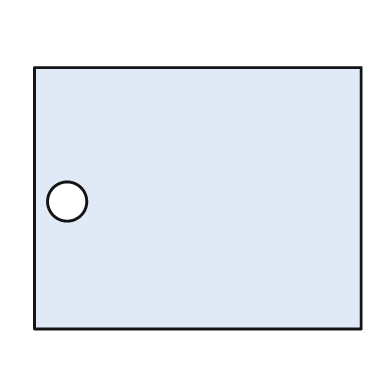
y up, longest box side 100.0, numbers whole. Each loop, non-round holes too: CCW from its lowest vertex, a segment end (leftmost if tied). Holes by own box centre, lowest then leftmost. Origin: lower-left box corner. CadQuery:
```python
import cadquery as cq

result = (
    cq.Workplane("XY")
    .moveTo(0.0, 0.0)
    .lineTo(100.0, 0.0)
    .lineTo(100.0, 80.0)
    .lineTo(0.0, 80.0)
    .close()
    .moveTo(10.0, 39.0)
    .circle(6.0)
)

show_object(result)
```